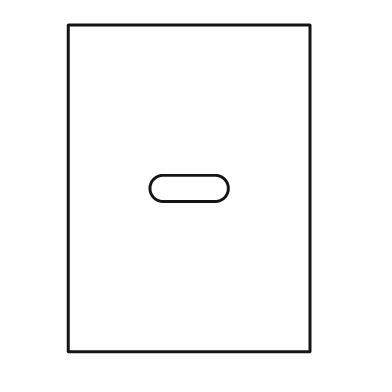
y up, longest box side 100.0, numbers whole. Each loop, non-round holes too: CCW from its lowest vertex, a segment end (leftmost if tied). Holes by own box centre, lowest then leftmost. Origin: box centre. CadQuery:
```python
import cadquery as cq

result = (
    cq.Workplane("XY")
    .moveTo(-37.0, -50.0)
    .lineTo(37.0, -50.0)
    .lineTo(37.0, 50.0)
    .lineTo(-37.0, 50.0)
    .close()
    .moveTo(-8.0, -4.0)
    .lineTo(8.0, -4.0)
    .threePointArc((12.0, 0.0), (8.0, 4.0))
    .lineTo(-8.0, 4.0)
    .threePointArc((-12.0, 0.0), (-8.0, -4.0))
    .close()
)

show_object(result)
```